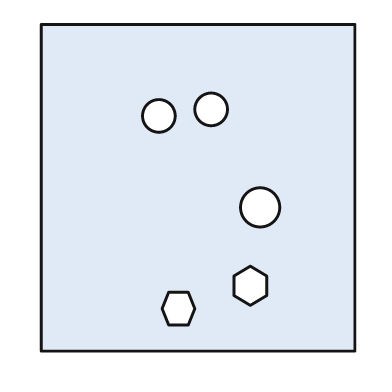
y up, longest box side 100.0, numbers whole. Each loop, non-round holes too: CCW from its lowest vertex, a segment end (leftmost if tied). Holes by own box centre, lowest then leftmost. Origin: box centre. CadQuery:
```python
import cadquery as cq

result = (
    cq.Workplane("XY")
    .moveTo(-48.0, -50.0)
    .lineTo(48.0, -50.0)
    .lineTo(48.0, 50.0)
    .lineTo(-48.0, 50.0)
    .close()
    .moveTo(-9.0, -42.0)
    .lineTo(-3.0, -42.0)
    .lineTo(-1.0, -37.0)
    .lineTo(-3.0, -32.0)
    .lineTo(-9.0, -32.0)
    .lineTo(-11.0, -37.0)
    .close()
    .moveTo(16.0, -36.0)
    .lineTo(21.0, -33.0)
    .lineTo(21.0, -27.0)
    .lineTo(16.0, -24.0)
    .lineTo(11.0, -27.0)
    .lineTo(11.0, -33.0)
    .close()
    .moveTo(19.0, -6.0)
    .circle(6.0)
    .moveTo(-12.0, 22.0)
    .circle(5.0)
    .moveTo(4.0, 24.0)
    .circle(5.0)
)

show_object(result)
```